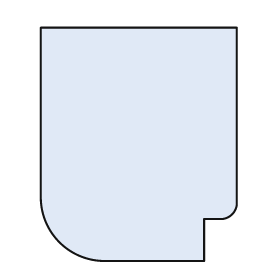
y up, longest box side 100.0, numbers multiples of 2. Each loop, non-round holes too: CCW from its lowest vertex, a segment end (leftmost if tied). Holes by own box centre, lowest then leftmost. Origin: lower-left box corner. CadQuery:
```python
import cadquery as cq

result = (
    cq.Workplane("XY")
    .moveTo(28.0, 0.0)
    .lineTo(70.0, 0.0)
    .lineTo(70.0, 18.0)
    .lineTo(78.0, 18.0)
    .threePointArc((82.0, 20.0), (84.0, 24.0))
    .lineTo(84.0, 100.0)
    .lineTo(0.0, 100.0)
    .lineTo(0.0, 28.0)
    .threePointArc((8.0, 8.0), (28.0, 0.0))
    .close()
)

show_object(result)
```